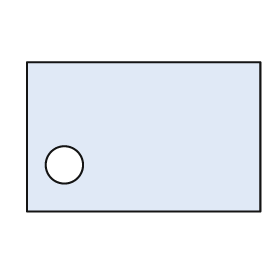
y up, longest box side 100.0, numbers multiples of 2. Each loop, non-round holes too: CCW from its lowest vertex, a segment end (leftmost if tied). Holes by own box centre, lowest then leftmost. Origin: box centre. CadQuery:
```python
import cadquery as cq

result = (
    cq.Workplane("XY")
    .moveTo(-50.0, -32.0)
    .lineTo(50.0, -32.0)
    .lineTo(50.0, 32.0)
    .lineTo(-50.0, 32.0)
    .close()
    .moveTo(-34.0, -12.0)
    .circle(8.0)
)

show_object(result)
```